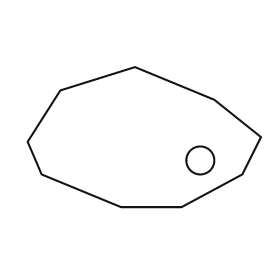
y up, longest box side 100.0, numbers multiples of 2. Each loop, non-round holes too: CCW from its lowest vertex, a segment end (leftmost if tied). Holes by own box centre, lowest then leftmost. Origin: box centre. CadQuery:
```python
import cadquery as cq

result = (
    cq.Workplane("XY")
    .moveTo(-10.0, -30.0)
    .lineTo(16.0, -30.0)
    .lineTo(42.0, -16.0)
    .lineTo(50.0, 0.0)
    .lineTo(30.0, 16.0)
    .lineTo(-4.0, 30.0)
    .lineTo(-36.0, 20.0)
    .lineTo(-50.0, -2.0)
    .lineTo(-44.0, -16.0)
    .close()
    .moveTo(24.0, -10.0)
    .circle(6.0)
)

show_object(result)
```